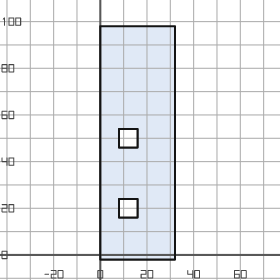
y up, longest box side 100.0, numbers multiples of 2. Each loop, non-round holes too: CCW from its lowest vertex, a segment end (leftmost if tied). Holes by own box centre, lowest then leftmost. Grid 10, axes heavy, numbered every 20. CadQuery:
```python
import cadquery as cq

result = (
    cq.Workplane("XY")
    .moveTo(0.0, -2.0)
    .lineTo(32.0, -2.0)
    .lineTo(32.0, 98.0)
    .lineTo(0.0, 98.0)
    .close()
    .moveTo(8.0, 16.0)
    .lineTo(16.0, 16.0)
    .lineTo(16.0, 24.0)
    .lineTo(8.0, 24.0)
    .close()
    .moveTo(8.0, 46.0)
    .lineTo(16.0, 46.0)
    .lineTo(16.0, 54.0)
    .lineTo(8.0, 54.0)
    .close()
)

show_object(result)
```